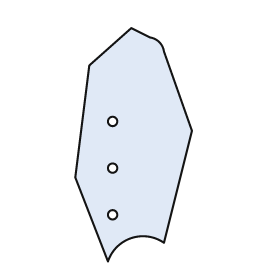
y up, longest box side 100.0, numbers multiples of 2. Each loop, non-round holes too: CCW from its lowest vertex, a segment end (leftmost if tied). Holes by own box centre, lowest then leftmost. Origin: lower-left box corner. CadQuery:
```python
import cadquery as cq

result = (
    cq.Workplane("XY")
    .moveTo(14.0, 0.0)
    .threePointArc((24.0, 10.0), (38.0, 8.0))
    .lineTo(50.0, 56.0)
    .lineTo(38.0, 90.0)
    .threePointArc((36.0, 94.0), (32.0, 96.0))
    .lineTo(24.0, 100.0)
    .lineTo(6.0, 84.0)
    .lineTo(0.0, 36.0)
    .close()
    .moveTo(16.0, 20.0)
    .circle(2.0)
    .moveTo(16.0, 40.0)
    .circle(2.0)
    .moveTo(16.0, 60.0)
    .circle(2.0)
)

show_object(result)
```